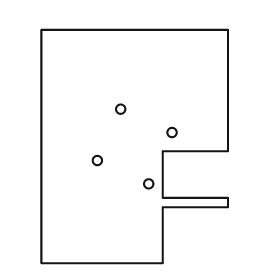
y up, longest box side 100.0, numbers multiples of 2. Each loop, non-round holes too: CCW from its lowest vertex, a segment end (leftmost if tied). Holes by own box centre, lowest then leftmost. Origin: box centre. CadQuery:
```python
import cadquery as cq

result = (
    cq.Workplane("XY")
    .moveTo(-40.0, -50.0)
    .lineTo(12.0, -50.0)
    .lineTo(12.0, -26.0)
    .lineTo(40.0, -26.0)
    .lineTo(40.0, -22.0)
    .lineTo(12.0, -22.0)
    .lineTo(12.0, -2.0)
    .lineTo(40.0, -2.0)
    .lineTo(40.0, 50.0)
    .lineTo(-40.0, 50.0)
    .close()
    .moveTo(6.0, -16.0)
    .circle(2.0)
    .moveTo(-16.0, -6.0)
    .circle(2.0)
    .moveTo(16.0, 6.0)
    .circle(2.0)
    .moveTo(-6.0, 16.0)
    .circle(2.0)
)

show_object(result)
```